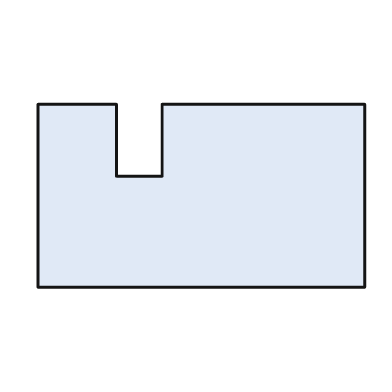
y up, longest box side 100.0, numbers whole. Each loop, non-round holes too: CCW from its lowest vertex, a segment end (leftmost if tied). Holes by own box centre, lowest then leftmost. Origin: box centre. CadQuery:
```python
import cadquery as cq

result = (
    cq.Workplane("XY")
    .moveTo(-50.0, -28.0)
    .lineTo(50.0, -28.0)
    .lineTo(50.0, 28.0)
    .lineTo(-12.0, 28.0)
    .lineTo(-12.0, 6.0)
    .lineTo(-26.0, 6.0)
    .lineTo(-26.0, 28.0)
    .lineTo(-50.0, 28.0)
    .close()
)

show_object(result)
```